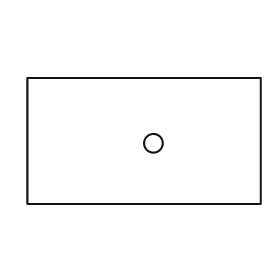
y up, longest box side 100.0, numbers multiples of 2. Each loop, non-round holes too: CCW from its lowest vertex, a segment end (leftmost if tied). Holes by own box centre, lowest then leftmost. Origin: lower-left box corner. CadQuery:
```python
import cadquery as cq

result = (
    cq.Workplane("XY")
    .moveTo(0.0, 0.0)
    .lineTo(100.0, 0.0)
    .lineTo(100.0, 54.0)
    .lineTo(0.0, 54.0)
    .close()
    .moveTo(54.0, 26.0)
    .circle(4.0)
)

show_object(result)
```